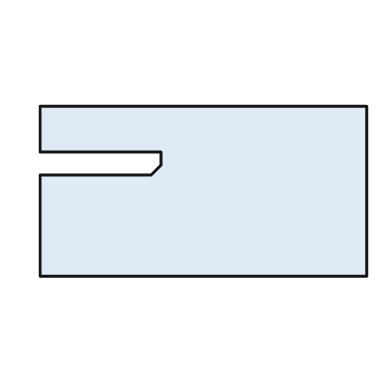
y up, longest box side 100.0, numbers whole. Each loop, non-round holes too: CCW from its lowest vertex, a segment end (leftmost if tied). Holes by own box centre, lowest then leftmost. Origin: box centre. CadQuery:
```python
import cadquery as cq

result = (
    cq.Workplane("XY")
    .moveTo(-50.0, -26.0)
    .lineTo(50.0, -26.0)
    .lineTo(50.0, 26.0)
    .lineTo(-50.0, 26.0)
    .lineTo(-50.0, 12.0)
    .lineTo(-13.0, 12.0)
    .lineTo(-13.0, 8.0)
    .lineTo(-16.0, 5.0)
    .lineTo(-50.0, 5.0)
    .close()
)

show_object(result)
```